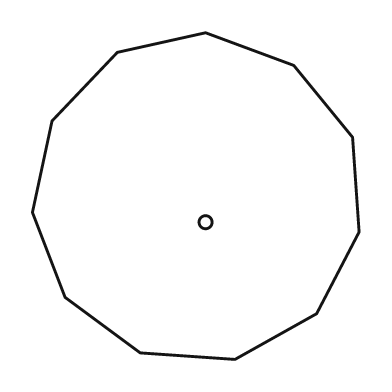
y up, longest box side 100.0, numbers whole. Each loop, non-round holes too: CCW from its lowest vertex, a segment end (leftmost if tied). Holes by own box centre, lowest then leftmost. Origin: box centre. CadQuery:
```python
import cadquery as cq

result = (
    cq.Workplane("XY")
    .moveTo(12.0, -50.0)
    .lineTo(37.0, -36.0)
    .lineTo(50.0, -11.0)
    .lineTo(48.0, 18.0)
    .lineTo(30.0, 40.0)
    .lineTo(3.0, 50.0)
    .lineTo(-24.0, 44.0)
    .lineTo(-44.0, 23.0)
    .lineTo(-50.0, -5.0)
    .lineTo(-40.0, -31.0)
    .lineTo(-17.0, -48.0)
    .close()
    .moveTo(3.0, -8.0)
    .circle(2.0)
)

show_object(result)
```